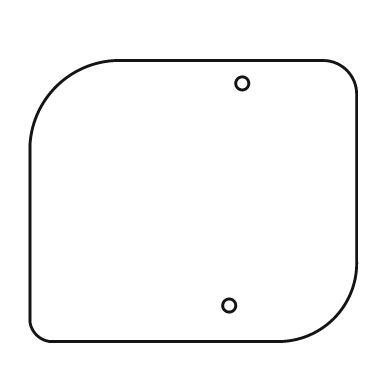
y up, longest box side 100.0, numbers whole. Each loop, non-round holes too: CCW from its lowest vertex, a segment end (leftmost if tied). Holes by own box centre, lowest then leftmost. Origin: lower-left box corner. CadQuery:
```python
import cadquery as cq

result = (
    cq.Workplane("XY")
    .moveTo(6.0, 0.0)
    .lineTo(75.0, 0.0)
    .threePointArc((93.0, 7.0), (100.0, 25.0))
    .lineTo(100.0, 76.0)
    .threePointArc((97.0, 83.0), (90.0, 86.0))
    .lineTo(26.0, 86.0)
    .threePointArc((8.0, 78.0), (0.0, 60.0))
    .lineTo(0.0, 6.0)
    .threePointArc((2.0, 2.0), (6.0, 0.0))
    .close()
    .moveTo(61.0, 11.0)
    .circle(2.0)
    .moveTo(65.0, 79.0)
    .circle(2.0)
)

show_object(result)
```